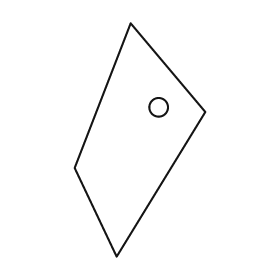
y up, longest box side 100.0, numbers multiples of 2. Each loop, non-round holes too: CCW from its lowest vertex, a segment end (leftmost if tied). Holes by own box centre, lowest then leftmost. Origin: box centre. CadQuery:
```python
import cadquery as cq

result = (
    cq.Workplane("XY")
    .moveTo(-10.0, -50.0)
    .lineTo(28.0, 12.0)
    .lineTo(-4.0, 50.0)
    .lineTo(-28.0, -12.0)
    .close()
    .moveTo(8.0, 14.0)
    .circle(4.0)
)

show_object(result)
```